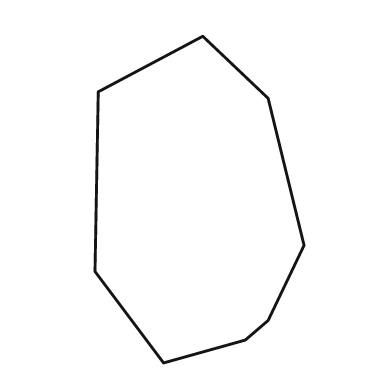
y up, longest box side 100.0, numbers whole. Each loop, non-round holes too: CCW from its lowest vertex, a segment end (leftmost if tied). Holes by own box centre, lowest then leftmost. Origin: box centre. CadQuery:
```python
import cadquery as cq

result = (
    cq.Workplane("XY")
    .moveTo(-11.0, -50.0)
    .lineTo(14.0, -43.0)
    .lineTo(21.0, -37.0)
    .lineTo(32.0, -14.0)
    .lineTo(21.0, 31.0)
    .lineTo(1.0, 50.0)
    .lineTo(-31.0, 33.0)
    .lineTo(-32.0, -22.0)
    .close()
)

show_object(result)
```